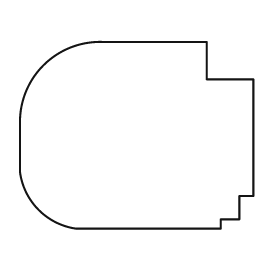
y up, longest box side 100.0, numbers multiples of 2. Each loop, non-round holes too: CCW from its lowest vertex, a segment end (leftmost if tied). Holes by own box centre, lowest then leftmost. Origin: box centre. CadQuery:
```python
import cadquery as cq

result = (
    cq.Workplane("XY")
    .moveTo(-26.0, -40.0)
    .lineTo(36.0, -40.0)
    .lineTo(36.0, -36.0)
    .lineTo(44.0, -36.0)
    .lineTo(44.0, -26.0)
    .lineTo(50.0, -26.0)
    .lineTo(50.0, 24.0)
    .lineTo(30.0, 24.0)
    .lineTo(30.0, 40.0)
    .lineTo(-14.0, 40.0)
    .threePointArc((-40.0, 30.0), (-50.0, 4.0))
    .lineTo(-50.0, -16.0)
    .threePointArc((-42.0, -32.0), (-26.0, -40.0))
    .close()
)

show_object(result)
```